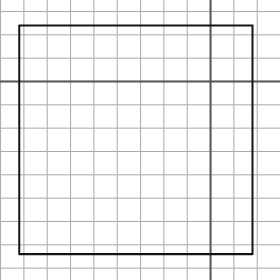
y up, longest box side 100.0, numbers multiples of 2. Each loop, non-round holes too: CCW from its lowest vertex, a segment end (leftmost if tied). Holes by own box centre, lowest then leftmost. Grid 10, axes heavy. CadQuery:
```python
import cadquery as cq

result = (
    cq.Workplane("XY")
    .moveTo(-82.0, -74.0)
    .lineTo(18.0, -74.0)
    .lineTo(18.0, 24.0)
    .lineTo(-82.0, 24.0)
    .close()
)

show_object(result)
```